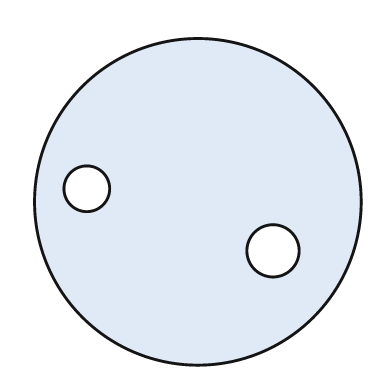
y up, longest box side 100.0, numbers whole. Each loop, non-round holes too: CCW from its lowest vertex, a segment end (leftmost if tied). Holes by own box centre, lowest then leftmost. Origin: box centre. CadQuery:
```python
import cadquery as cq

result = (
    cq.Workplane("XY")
    .moveTo(0.0, 0.0)
    .circle(50.0)
    .moveTo(23.0, -15.0)
    .circle(8.0)
    .moveTo(-34.0, 4.0)
    .circle(7.0)
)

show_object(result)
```